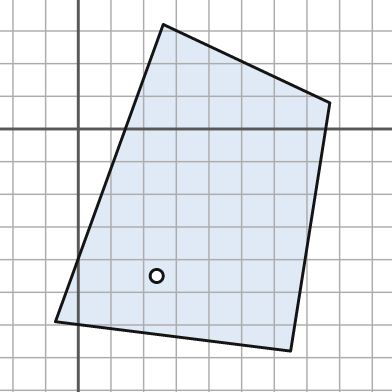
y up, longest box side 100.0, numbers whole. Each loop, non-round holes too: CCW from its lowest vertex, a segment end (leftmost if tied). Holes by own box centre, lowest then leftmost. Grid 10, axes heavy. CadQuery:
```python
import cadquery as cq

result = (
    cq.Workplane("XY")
    .moveTo(65.0, -68.0)
    .lineTo(77.0, 8.0)
    .lineTo(26.0, 32.0)
    .lineTo(-7.0, -59.0)
    .close()
    .moveTo(24.0, -45.0)
    .circle(2.0)
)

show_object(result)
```